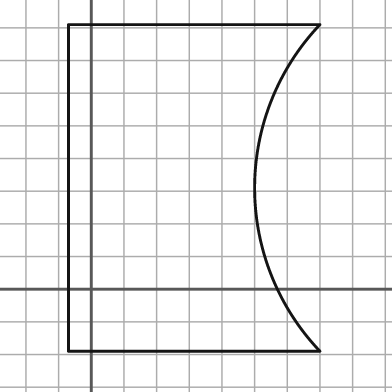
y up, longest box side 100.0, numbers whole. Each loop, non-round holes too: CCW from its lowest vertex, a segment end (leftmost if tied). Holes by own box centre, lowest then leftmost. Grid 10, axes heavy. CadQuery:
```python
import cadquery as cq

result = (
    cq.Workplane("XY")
    .moveTo(-7.0, -19.0)
    .lineTo(70.0, -19.0)
    .threePointArc((50.0, 31.0), (70.0, 81.0))
    .lineTo(-7.0, 81.0)
    .close()
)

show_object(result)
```